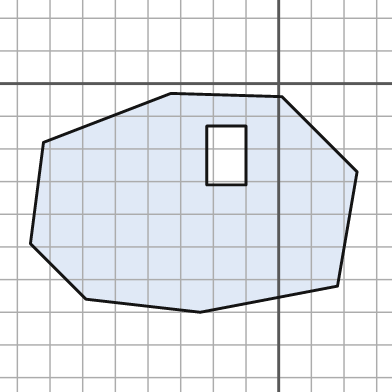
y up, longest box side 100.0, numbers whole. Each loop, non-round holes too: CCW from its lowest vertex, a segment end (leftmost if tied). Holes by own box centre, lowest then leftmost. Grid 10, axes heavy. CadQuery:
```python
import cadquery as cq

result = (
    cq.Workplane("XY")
    .moveTo(-24.0, -70.0)
    .lineTo(18.0, -62.0)
    .lineTo(24.0, -27.0)
    .lineTo(1.0, -4.0)
    .lineTo(-33.0, -3.0)
    .lineTo(-72.0, -18.0)
    .lineTo(-76.0, -49.0)
    .lineTo(-59.0, -66.0)
    .close()
    .moveTo(-22.0, -31.0)
    .lineTo(-10.0, -31.0)
    .lineTo(-10.0, -13.0)
    .lineTo(-22.0, -13.0)
    .close()
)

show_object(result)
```